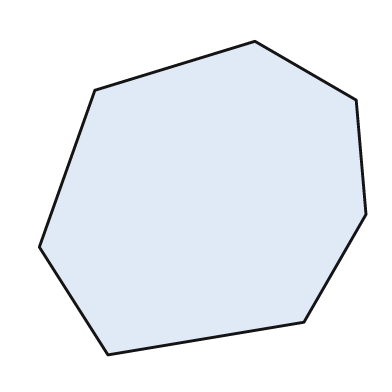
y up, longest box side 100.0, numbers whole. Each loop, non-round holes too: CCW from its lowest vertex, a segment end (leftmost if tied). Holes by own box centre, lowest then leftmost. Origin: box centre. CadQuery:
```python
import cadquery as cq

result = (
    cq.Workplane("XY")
    .moveTo(-29.0, -48.0)
    .lineTo(31.0, -38.0)
    .lineTo(50.0, -5.0)
    .lineTo(47.0, 30.0)
    .lineTo(16.0, 48.0)
    .lineTo(-33.0, 33.0)
    .lineTo(-50.0, -15.0)
    .close()
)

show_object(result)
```